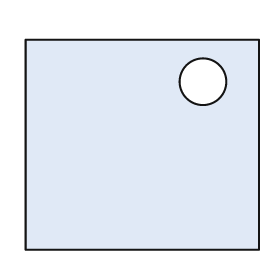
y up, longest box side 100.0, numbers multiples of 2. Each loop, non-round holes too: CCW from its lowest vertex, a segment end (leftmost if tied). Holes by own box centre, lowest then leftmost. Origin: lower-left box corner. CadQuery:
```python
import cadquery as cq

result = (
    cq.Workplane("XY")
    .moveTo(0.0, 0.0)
    .lineTo(100.0, 0.0)
    .lineTo(100.0, 90.0)
    .lineTo(0.0, 90.0)
    .close()
    .moveTo(76.0, 72.0)
    .circle(10.0)
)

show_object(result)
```